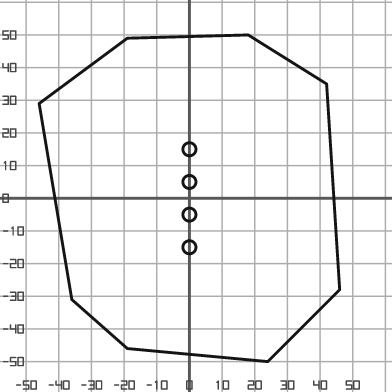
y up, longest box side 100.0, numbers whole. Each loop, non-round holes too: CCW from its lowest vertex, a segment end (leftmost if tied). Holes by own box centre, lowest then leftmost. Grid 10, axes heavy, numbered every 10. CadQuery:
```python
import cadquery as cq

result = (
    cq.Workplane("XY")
    .moveTo(24.0, -50.0)
    .lineTo(46.0, -28.0)
    .lineTo(42.0, 35.0)
    .lineTo(18.0, 50.0)
    .lineTo(-19.0, 49.0)
    .lineTo(-46.0, 29.0)
    .lineTo(-36.0, -31.0)
    .lineTo(-19.0, -46.0)
    .close()
    .moveTo(0.0, -15.0)
    .circle(2.0)
    .moveTo(0.0, -5.0)
    .circle(2.0)
    .moveTo(0.0, 5.0)
    .circle(2.0)
    .moveTo(0.0, 15.0)
    .circle(2.0)
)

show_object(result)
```